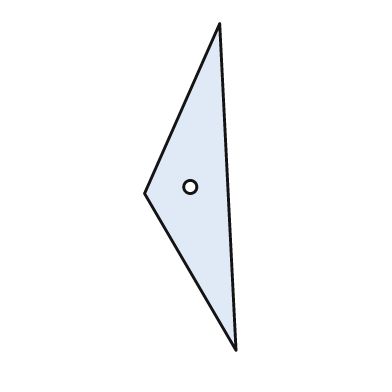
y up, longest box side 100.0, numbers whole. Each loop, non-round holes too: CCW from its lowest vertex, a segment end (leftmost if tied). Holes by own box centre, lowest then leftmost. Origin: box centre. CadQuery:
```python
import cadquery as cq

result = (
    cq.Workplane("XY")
    .moveTo(14.0, -50.0)
    .lineTo(9.0, 50.0)
    .lineTo(-14.0, -2.0)
    .close()
    .moveTo(0.0, 0.0)
    .circle(2.0)
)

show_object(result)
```